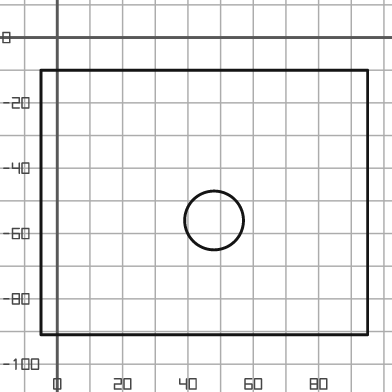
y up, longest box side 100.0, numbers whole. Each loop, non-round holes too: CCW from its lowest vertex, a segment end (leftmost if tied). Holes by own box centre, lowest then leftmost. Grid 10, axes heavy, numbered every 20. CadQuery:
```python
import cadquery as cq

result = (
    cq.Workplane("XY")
    .moveTo(-5.0, -91.0)
    .lineTo(95.0, -91.0)
    .lineTo(95.0, -10.0)
    .lineTo(-5.0, -10.0)
    .close()
    .moveTo(48.0, -56.0)
    .circle(9.0)
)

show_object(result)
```